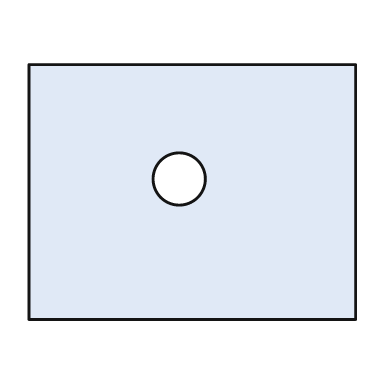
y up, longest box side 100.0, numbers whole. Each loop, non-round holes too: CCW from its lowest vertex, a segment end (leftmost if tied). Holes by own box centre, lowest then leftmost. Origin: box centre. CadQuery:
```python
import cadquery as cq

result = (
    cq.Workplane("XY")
    .moveTo(-50.0, -39.0)
    .lineTo(50.0, -39.0)
    .lineTo(50.0, 39.0)
    .lineTo(-50.0, 39.0)
    .close()
    .moveTo(-4.0, 4.0)
    .circle(8.0)
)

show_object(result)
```